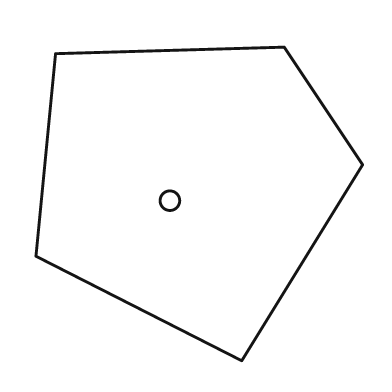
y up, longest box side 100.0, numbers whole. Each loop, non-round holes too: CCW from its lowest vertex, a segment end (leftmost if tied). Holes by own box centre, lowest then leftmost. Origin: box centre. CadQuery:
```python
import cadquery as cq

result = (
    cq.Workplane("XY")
    .moveTo(13.0, -48.0)
    .lineTo(50.0, 12.0)
    .lineTo(26.0, 48.0)
    .lineTo(-44.0, 46.0)
    .lineTo(-50.0, -16.0)
    .close()
    .moveTo(-9.0, 1.0)
    .circle(3.0)
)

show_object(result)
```